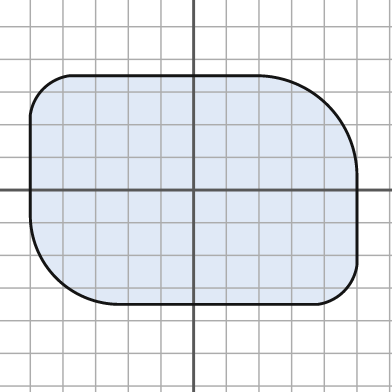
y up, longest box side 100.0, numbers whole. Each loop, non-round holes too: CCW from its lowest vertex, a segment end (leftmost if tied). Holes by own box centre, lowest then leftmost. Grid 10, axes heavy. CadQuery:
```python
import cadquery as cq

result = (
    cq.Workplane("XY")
    .moveTo(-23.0, -35.0)
    .lineTo(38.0, -35.0)
    .threePointArc((46.0, -31.0), (50.0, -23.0))
    .lineTo(50.0, 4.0)
    .threePointArc((41.0, 26.0), (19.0, 35.0))
    .lineTo(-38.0, 35.0)
    .threePointArc((-46.0, 31.0), (-50.0, 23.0))
    .lineTo(-50.0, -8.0)
    .threePointArc((-42.0, -27.0), (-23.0, -35.0))
    .close()
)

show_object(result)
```